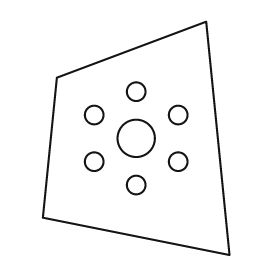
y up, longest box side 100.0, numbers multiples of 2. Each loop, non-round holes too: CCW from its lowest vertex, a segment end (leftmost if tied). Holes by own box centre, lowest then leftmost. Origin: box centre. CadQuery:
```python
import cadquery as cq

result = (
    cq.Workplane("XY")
    .moveTo(40.0, -50.0)
    .lineTo(30.0, 50.0)
    .lineTo(-34.0, 26.0)
    .lineTo(-40.0, -34.0)
    .close()
    .moveTo(0.0, -20.0)
    .circle(4.0)
    .moveTo(-18.0, -10.0)
    .circle(4.0)
    .moveTo(18.0, -10.0)
    .circle(4.0)
    .moveTo(0.0, 0.0)
    .circle(8.0)
    .moveTo(-18.0, 10.0)
    .circle(4.0)
    .moveTo(18.0, 10.0)
    .circle(4.0)
    .moveTo(0.0, 20.0)
    .circle(4.0)
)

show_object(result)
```